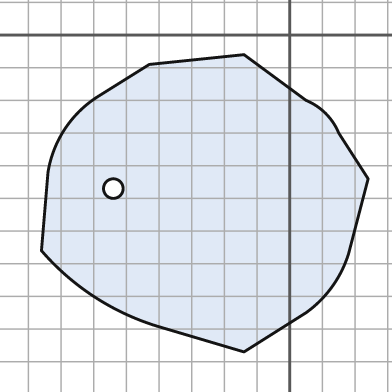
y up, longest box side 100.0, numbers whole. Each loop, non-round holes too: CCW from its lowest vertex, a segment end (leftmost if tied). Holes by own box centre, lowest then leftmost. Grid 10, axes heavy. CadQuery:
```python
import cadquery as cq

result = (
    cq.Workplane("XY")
    .moveTo(-14.0, -97.0)
    .lineTo(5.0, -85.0)
    .threePointArc((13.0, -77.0), (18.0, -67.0))
    .lineTo(24.0, -44.0)
    .lineTo(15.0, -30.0)
    .threePointArc((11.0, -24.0), (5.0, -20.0))
    .lineTo(-14.0, -6.0)
    .lineTo(-43.0, -9.0)
    .lineTo(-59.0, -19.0)
    .threePointArc((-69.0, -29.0), (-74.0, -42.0))
    .lineTo(-76.0, -66.0)
    .threePointArc((-60.0, -80.0), (-41.0, -89.0))
    .close()
    .moveTo(-54.0, -47.0)
    .circle(3.0)
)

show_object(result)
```